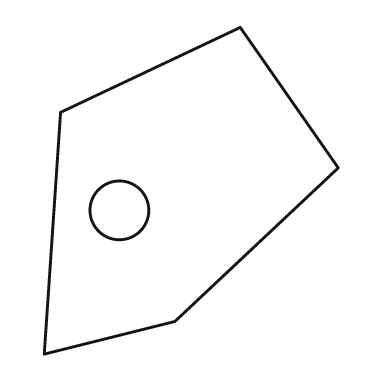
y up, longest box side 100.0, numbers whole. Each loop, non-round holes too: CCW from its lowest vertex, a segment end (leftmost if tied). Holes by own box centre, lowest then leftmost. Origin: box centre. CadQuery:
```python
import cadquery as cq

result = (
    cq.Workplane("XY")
    .moveTo(-45.0, -50.0)
    .lineTo(-5.0, -40.0)
    .lineTo(45.0, 7.0)
    .lineTo(15.0, 50.0)
    .lineTo(-40.0, 24.0)
    .close()
    .moveTo(-22.0, -6.0)
    .circle(9.0)
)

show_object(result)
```